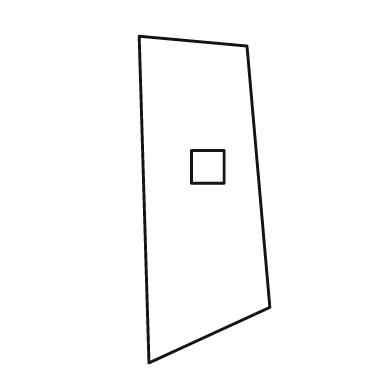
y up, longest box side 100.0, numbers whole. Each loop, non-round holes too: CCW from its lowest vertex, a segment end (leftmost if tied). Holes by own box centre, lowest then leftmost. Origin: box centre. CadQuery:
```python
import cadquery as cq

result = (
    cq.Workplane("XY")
    .moveTo(-17.0, -50.0)
    .lineTo(20.0, -33.0)
    .lineTo(13.0, 47.0)
    .lineTo(-20.0, 50.0)
    .close()
    .moveTo(-4.0, 5.0)
    .lineTo(6.0, 5.0)
    .lineTo(6.0, 15.0)
    .lineTo(-4.0, 15.0)
    .close()
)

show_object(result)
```